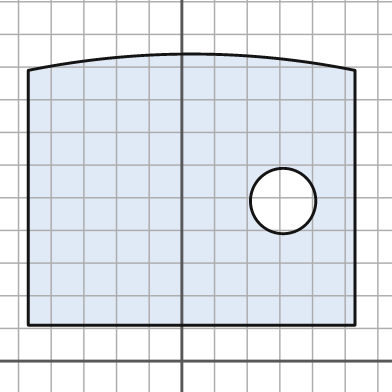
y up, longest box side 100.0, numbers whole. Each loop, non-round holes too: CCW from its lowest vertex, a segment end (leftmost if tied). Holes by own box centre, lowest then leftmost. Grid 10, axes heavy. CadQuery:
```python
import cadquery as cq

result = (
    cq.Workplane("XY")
    .moveTo(-47.0, 11.0)
    .lineTo(53.0, 11.0)
    .lineTo(53.0, 89.0)
    .threePointArc((3.0, 94.0), (-47.0, 89.0))
    .close()
    .moveTo(31.0, 49.0)
    .circle(10.0)
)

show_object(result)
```